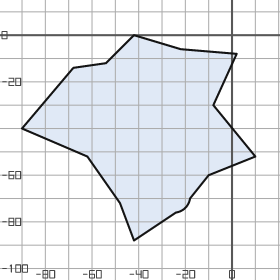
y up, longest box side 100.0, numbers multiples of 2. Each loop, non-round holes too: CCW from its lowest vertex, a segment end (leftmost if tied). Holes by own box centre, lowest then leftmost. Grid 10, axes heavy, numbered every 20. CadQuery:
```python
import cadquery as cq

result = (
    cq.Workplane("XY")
    .moveTo(-42.0, -88.0)
    .lineTo(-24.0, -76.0)
    .threePointArc((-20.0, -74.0), (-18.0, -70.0))
    .lineTo(-10.0, -60.0)
    .lineTo(10.0, -52.0)
    .lineTo(-8.0, -30.0)
    .lineTo(2.0, -8.0)
    .lineTo(-22.0, -6.0)
    .lineTo(-42.0, 0.0)
    .lineTo(-54.0, -12.0)
    .lineTo(-68.0, -14.0)
    .lineTo(-90.0, -40.0)
    .lineTo(-62.0, -52.0)
    .lineTo(-48.0, -72.0)
    .close()
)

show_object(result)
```